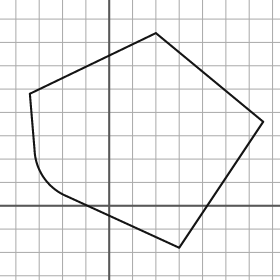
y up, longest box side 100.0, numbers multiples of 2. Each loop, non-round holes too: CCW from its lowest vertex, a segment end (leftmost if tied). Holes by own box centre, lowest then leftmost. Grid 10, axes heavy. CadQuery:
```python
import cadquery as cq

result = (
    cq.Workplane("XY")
    .moveTo(30.0, -18.0)
    .lineTo(66.0, 36.0)
    .lineTo(20.0, 74.0)
    .lineTo(-34.0, 48.0)
    .lineTo(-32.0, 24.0)
    .threePointArc((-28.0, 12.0), (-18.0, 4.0))
    .close()
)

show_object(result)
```